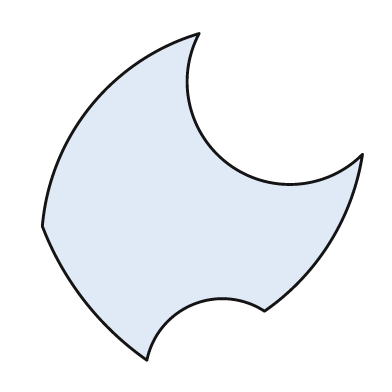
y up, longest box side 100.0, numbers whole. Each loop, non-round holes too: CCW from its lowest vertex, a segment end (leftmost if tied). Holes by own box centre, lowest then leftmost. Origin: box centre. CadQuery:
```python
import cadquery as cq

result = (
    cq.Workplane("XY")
    .moveTo(-17.0, -50.0)
    .threePointArc((-3.0, -33.0), (19.0, -35.0))
    .threePointArc((39.0, -14.0), (49.0, 13.0))
    .threePointArc((8.0, 10.0), (-1.0, 50.0))
    .threePointArc((-34.0, 28.0), (-49.0, -9.0))
    .threePointArc((-36.0, -32.0), (-17.0, -50.0))
    .close()
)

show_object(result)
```